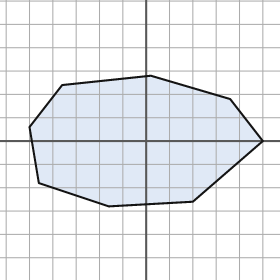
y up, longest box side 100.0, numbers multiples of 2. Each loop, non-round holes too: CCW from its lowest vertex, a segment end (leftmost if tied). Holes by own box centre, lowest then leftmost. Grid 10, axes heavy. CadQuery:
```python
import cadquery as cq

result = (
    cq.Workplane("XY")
    .moveTo(-16.0, -28.0)
    .lineTo(20.0, -26.0)
    .lineTo(50.0, 0.0)
    .lineTo(36.0, 18.0)
    .lineTo(2.0, 28.0)
    .lineTo(-36.0, 24.0)
    .lineTo(-50.0, 6.0)
    .lineTo(-46.0, -18.0)
    .close()
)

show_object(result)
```